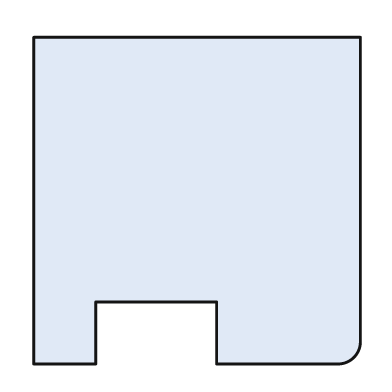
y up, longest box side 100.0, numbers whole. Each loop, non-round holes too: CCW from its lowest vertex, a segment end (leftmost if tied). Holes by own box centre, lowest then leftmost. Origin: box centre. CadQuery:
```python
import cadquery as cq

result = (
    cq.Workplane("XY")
    .moveTo(-50.0, -50.0)
    .lineTo(-31.0, -50.0)
    .lineTo(-31.0, -31.0)
    .lineTo(6.0, -31.0)
    .lineTo(6.0, -50.0)
    .lineTo(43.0, -50.0)
    .threePointArc((48.0, -48.0), (50.0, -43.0))
    .lineTo(50.0, 50.0)
    .lineTo(-50.0, 50.0)
    .close()
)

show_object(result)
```